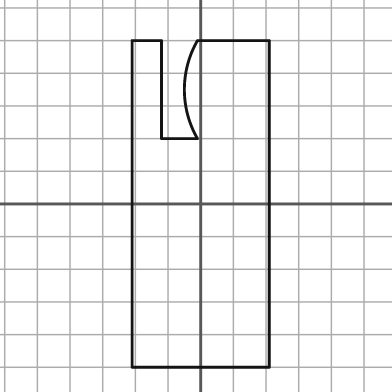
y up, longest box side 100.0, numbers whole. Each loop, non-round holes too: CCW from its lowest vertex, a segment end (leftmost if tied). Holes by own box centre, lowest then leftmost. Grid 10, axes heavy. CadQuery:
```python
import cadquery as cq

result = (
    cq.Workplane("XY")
    .moveTo(-21.0, -50.0)
    .lineTo(21.0, -50.0)
    .lineTo(21.0, 50.0)
    .lineTo(-1.0, 50.0)
    .threePointArc((-5.0, 35.0), (-1.0, 20.0))
    .lineTo(-12.0, 20.0)
    .lineTo(-12.0, 50.0)
    .lineTo(-21.0, 50.0)
    .close()
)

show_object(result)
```